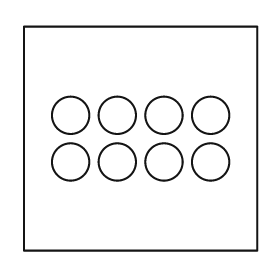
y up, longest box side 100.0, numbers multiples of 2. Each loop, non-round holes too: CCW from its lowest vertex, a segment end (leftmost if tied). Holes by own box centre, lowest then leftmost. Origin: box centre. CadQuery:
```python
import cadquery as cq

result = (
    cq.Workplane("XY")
    .moveTo(-50.0, -48.0)
    .lineTo(50.0, -48.0)
    .lineTo(50.0, 48.0)
    .lineTo(-50.0, 48.0)
    .close()
    .moveTo(-30.0, -10.0)
    .circle(8.0)
    .moveTo(-10.0, -10.0)
    .circle(8.0)
    .moveTo(10.0, -10.0)
    .circle(8.0)
    .moveTo(30.0, -10.0)
    .circle(8.0)
    .moveTo(-30.0, 10.0)
    .circle(8.0)
    .moveTo(-10.0, 10.0)
    .circle(8.0)
    .moveTo(10.0, 10.0)
    .circle(8.0)
    .moveTo(30.0, 10.0)
    .circle(8.0)
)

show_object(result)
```